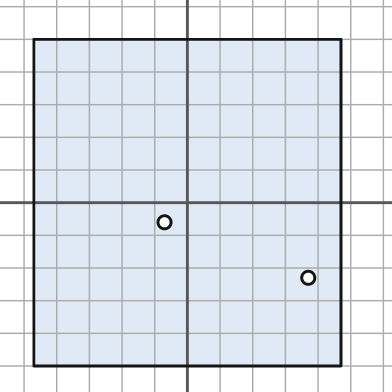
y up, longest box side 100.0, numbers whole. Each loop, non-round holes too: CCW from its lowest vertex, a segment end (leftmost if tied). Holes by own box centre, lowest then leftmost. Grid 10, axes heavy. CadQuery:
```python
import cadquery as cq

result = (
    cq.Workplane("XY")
    .moveTo(-47.0, -50.0)
    .lineTo(47.0, -50.0)
    .lineTo(47.0, 50.0)
    .lineTo(-47.0, 50.0)
    .close()
    .moveTo(37.0, -23.0)
    .circle(2.0)
    .moveTo(-7.0, -6.0)
    .circle(2.0)
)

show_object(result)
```